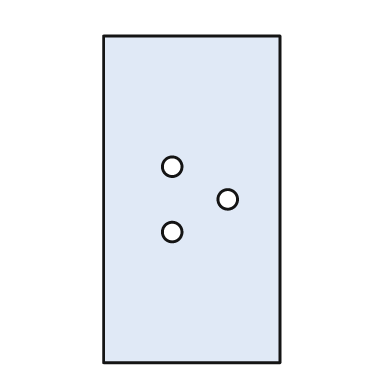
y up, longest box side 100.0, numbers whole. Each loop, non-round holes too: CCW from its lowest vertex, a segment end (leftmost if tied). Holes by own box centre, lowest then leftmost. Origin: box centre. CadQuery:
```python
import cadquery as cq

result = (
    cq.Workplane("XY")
    .moveTo(-27.0, -50.0)
    .lineTo(27.0, -50.0)
    .lineTo(27.0, 50.0)
    .lineTo(-27.0, 50.0)
    .close()
    .moveTo(-6.0, -10.0)
    .circle(3.0)
    .moveTo(11.0, 0.0)
    .circle(3.0)
    .moveTo(-6.0, 10.0)
    .circle(3.0)
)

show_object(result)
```